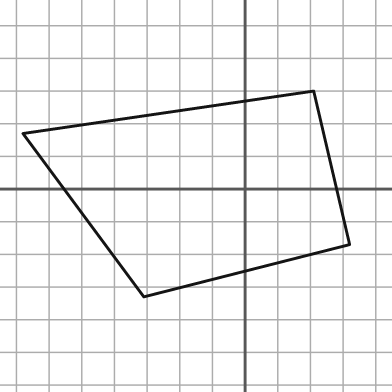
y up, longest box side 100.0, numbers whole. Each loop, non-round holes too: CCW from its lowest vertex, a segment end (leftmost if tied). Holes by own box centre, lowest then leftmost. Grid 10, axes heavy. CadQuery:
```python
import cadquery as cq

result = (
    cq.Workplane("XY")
    .moveTo(-31.0, -33.0)
    .lineTo(32.0, -17.0)
    .lineTo(21.0, 30.0)
    .lineTo(-68.0, 17.0)
    .close()
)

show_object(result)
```